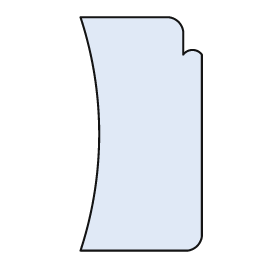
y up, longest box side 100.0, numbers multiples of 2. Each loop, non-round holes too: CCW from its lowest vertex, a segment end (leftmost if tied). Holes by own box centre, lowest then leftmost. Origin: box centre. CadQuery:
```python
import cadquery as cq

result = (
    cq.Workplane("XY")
    .moveTo(-26.0, -50.0)
    .lineTo(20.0, -50.0)
    .threePointArc((24.0, -48.0), (26.0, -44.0))
    .lineTo(26.0, 34.0)
    .threePointArc((22.0, 36.0), (18.0, 34.0))
    .lineTo(18.0, 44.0)
    .threePointArc((16.0, 48.0), (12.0, 50.0))
    .lineTo(-26.0, 50.0)
    .threePointArc((-18.0, 0.0), (-26.0, -50.0))
    .close()
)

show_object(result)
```